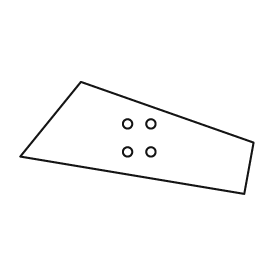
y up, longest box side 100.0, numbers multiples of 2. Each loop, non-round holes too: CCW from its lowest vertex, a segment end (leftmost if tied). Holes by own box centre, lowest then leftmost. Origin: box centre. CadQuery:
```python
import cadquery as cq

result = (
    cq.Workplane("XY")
    .moveTo(46.0, -24.0)
    .lineTo(50.0, -2.0)
    .lineTo(-24.0, 24.0)
    .lineTo(-50.0, -8.0)
    .close()
    .moveTo(-4.0, -6.0)
    .circle(2.0)
    .moveTo(6.0, -6.0)
    .circle(2.0)
    .moveTo(-4.0, 6.0)
    .circle(2.0)
    .moveTo(6.0, 6.0)
    .circle(2.0)
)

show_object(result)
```